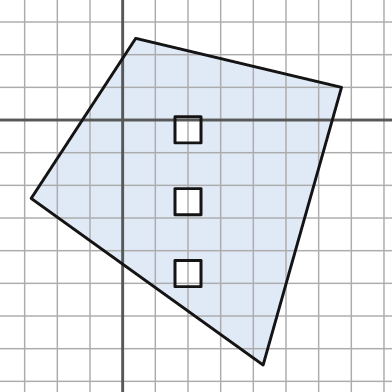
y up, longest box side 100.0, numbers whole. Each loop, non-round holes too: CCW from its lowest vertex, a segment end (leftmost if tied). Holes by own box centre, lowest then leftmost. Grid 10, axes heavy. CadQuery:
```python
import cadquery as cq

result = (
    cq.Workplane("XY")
    .moveTo(43.0, -75.0)
    .lineTo(67.0, 10.0)
    .lineTo(4.0, 25.0)
    .lineTo(-28.0, -24.0)
    .close()
    .moveTo(16.0, -51.0)
    .lineTo(24.0, -51.0)
    .lineTo(24.0, -43.0)
    .lineTo(16.0, -43.0)
    .close()
    .moveTo(16.0, -29.0)
    .lineTo(24.0, -29.0)
    .lineTo(24.0, -21.0)
    .lineTo(16.0, -21.0)
    .close()
    .moveTo(16.0, -7.0)
    .lineTo(24.0, -7.0)
    .lineTo(24.0, 1.0)
    .lineTo(16.0, 1.0)
    .close()
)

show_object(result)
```